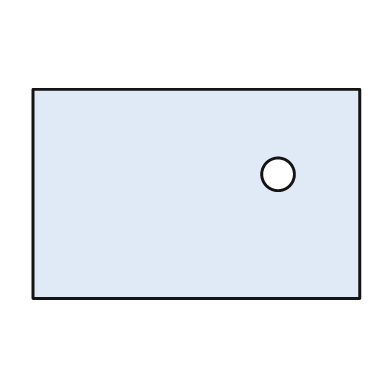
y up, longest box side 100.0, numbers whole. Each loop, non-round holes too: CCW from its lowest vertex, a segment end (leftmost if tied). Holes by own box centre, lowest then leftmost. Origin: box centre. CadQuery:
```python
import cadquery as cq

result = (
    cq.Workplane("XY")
    .moveTo(-50.0, -32.0)
    .lineTo(50.0, -32.0)
    .lineTo(50.0, 32.0)
    .lineTo(-50.0, 32.0)
    .close()
    .moveTo(25.0, 6.0)
    .circle(5.0)
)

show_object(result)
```